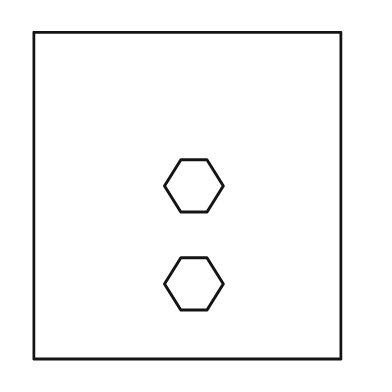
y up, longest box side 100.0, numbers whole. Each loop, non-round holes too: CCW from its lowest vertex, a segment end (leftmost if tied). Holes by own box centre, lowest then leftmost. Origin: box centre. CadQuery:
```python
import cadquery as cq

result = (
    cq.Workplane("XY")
    .moveTo(-47.0, -50.0)
    .lineTo(47.0, -50.0)
    .lineTo(47.0, 50.0)
    .lineTo(-47.0, 50.0)
    .close()
    .moveTo(-2.0, -35.0)
    .lineTo(6.0, -35.0)
    .lineTo(11.0, -27.0)
    .lineTo(6.0, -19.0)
    .lineTo(-2.0, -19.0)
    .lineTo(-7.0, -27.0)
    .close()
    .moveTo(-2.0, -5.0)
    .lineTo(6.0, -5.0)
    .lineTo(11.0, 3.0)
    .lineTo(6.0, 11.0)
    .lineTo(-2.0, 11.0)
    .lineTo(-7.0, 3.0)
    .close()
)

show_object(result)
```